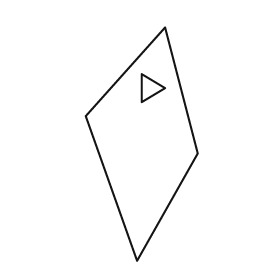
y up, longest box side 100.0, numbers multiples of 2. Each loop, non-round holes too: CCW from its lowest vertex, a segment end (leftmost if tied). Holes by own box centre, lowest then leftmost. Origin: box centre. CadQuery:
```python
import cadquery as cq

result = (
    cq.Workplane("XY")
    .moveTo(-2.0, -50.0)
    .lineTo(24.0, -4.0)
    .lineTo(10.0, 50.0)
    .lineTo(-24.0, 12.0)
    .close()
    .moveTo(0.0, 18.0)
    .lineTo(10.0, 24.0)
    .lineTo(0.0, 30.0)
    .close()
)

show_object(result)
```